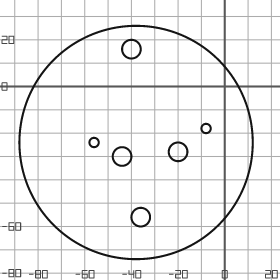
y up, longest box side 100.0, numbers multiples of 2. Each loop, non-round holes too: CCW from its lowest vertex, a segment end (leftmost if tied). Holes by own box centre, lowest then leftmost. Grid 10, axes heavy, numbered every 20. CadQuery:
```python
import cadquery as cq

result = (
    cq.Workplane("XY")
    .moveTo(-38.0, -24.0)
    .circle(50.0)
    .moveTo(-36.0, -56.0)
    .circle(4.0)
    .moveTo(-44.0, -30.0)
    .circle(4.0)
    .moveTo(-20.0, -28.0)
    .circle(4.0)
    .moveTo(-56.0, -24.0)
    .circle(2.0)
    .moveTo(-8.0, -18.0)
    .circle(2.0)
    .moveTo(-40.0, 16.0)
    .circle(4.0)
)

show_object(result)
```